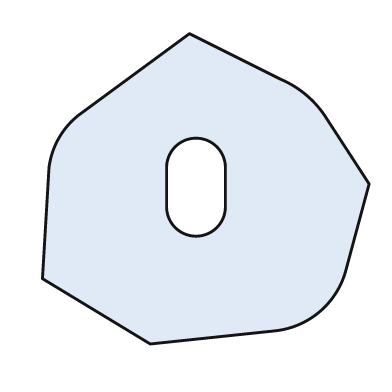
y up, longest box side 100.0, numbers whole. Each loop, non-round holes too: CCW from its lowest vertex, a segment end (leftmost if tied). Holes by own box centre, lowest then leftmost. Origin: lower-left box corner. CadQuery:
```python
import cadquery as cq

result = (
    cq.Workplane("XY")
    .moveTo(33.0, 0.0)
    .lineTo(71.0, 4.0)
    .threePointArc((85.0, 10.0), (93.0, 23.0))
    .lineTo(100.0, 49.0)
    .lineTo(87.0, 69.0)
    .threePointArc((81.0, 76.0), (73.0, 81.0))
    .lineTo(45.0, 95.0)
    .lineTo(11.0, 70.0)
    .threePointArc((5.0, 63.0), (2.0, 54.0))
    .lineTo(0.0, 20.0)
    .close()
    .moveTo(38.0, 42.0)
    .threePointArc((47.0, 33.0), (56.0, 42.0))
    .lineTo(56.0, 54.0)
    .threePointArc((47.0, 63.0), (38.0, 54.0))
    .close()
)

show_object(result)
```